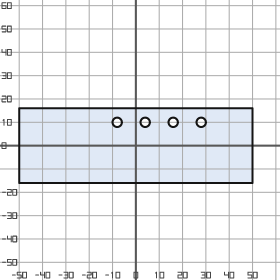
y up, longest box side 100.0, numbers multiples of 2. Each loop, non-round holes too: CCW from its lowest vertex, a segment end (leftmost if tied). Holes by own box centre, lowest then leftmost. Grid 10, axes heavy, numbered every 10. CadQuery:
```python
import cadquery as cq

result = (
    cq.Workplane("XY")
    .moveTo(-50.0, -16.0)
    .lineTo(50.0, -16.0)
    .lineTo(50.0, 16.0)
    .lineTo(-50.0, 16.0)
    .close()
    .moveTo(-8.0, 10.0)
    .circle(2.0)
    .moveTo(4.0, 10.0)
    .circle(2.0)
    .moveTo(16.0, 10.0)
    .circle(2.0)
    .moveTo(28.0, 10.0)
    .circle(2.0)
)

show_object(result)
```